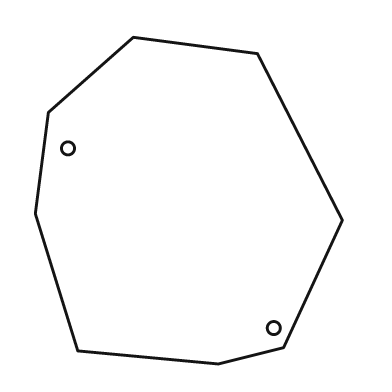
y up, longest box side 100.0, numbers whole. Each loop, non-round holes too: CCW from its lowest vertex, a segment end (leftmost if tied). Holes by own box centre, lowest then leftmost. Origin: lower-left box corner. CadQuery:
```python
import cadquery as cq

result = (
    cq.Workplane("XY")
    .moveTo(56.0, 0.0)
    .lineTo(76.0, 5.0)
    .lineTo(94.0, 44.0)
    .lineTo(68.0, 95.0)
    .lineTo(30.0, 100.0)
    .lineTo(4.0, 77.0)
    .lineTo(0.0, 46.0)
    .lineTo(13.0, 4.0)
    .close()
    .moveTo(73.0, 11.0)
    .circle(2.0)
    .moveTo(10.0, 66.0)
    .circle(2.0)
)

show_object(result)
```